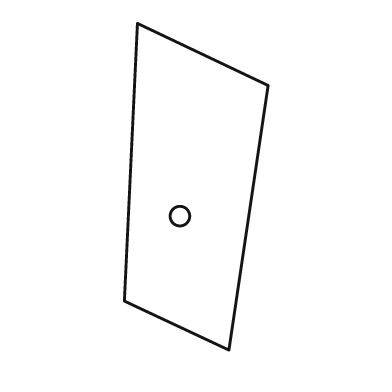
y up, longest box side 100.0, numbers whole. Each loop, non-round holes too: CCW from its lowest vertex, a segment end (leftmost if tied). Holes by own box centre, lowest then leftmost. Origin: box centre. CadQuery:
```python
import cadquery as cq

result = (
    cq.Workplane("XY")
    .moveTo(10.0, -50.0)
    .lineTo(22.0, 31.0)
    .lineTo(-18.0, 50.0)
    .lineTo(-22.0, -35.0)
    .close()
    .moveTo(-5.0, -9.0)
    .circle(3.0)
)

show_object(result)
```